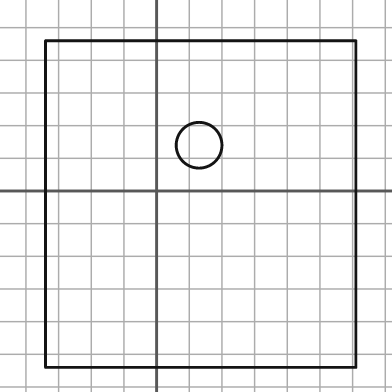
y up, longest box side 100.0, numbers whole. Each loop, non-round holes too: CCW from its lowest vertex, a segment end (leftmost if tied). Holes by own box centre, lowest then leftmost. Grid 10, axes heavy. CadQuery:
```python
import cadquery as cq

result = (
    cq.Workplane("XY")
    .moveTo(-34.0, -54.0)
    .lineTo(61.0, -54.0)
    .lineTo(61.0, 46.0)
    .lineTo(-34.0, 46.0)
    .close()
    .moveTo(13.0, 14.0)
    .circle(7.0)
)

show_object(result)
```